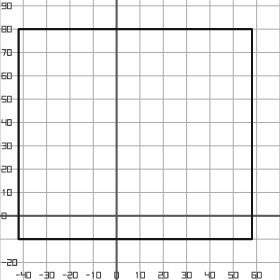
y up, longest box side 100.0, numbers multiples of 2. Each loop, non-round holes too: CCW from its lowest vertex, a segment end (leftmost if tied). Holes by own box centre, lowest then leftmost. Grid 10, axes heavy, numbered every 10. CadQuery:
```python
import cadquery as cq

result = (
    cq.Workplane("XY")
    .moveTo(-42.0, -10.0)
    .lineTo(58.0, -10.0)
    .lineTo(58.0, 80.0)
    .lineTo(-42.0, 80.0)
    .close()
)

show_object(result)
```